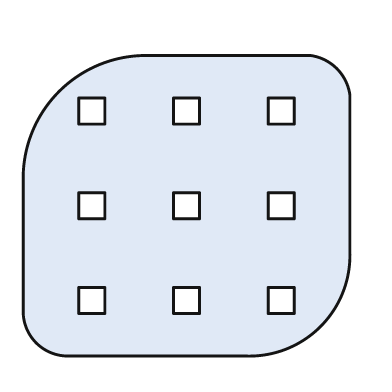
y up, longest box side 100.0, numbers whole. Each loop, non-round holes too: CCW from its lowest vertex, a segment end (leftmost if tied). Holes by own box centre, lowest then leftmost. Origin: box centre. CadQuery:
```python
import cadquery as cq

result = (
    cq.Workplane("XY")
    .moveTo(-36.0, -46.0)
    .lineTo(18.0, -46.0)
    .threePointArc((41.0, -37.0), (50.0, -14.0))
    .lineTo(50.0, 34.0)
    .threePointArc((46.0, 42.0), (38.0, 46.0))
    .lineTo(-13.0, 46.0)
    .threePointArc((-39.0, 35.0), (-50.0, 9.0))
    .lineTo(-50.0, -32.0)
    .threePointArc((-46.0, -42.0), (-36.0, -46.0))
    .close()
    .moveTo(-33.0, -33.0)
    .lineTo(-25.0, -33.0)
    .lineTo(-25.0, -25.0)
    .lineTo(-33.0, -25.0)
    .close()
    .moveTo(-4.0, -33.0)
    .lineTo(4.0, -33.0)
    .lineTo(4.0, -25.0)
    .lineTo(-4.0, -25.0)
    .close()
    .moveTo(25.0, -33.0)
    .lineTo(33.0, -33.0)
    .lineTo(33.0, -25.0)
    .lineTo(25.0, -25.0)
    .close()
    .moveTo(-33.0, -4.0)
    .lineTo(-25.0, -4.0)
    .lineTo(-25.0, 4.0)
    .lineTo(-33.0, 4.0)
    .close()
    .moveTo(-4.0, -4.0)
    .lineTo(4.0, -4.0)
    .lineTo(4.0, 4.0)
    .lineTo(-4.0, 4.0)
    .close()
    .moveTo(25.0, -4.0)
    .lineTo(33.0, -4.0)
    .lineTo(33.0, 4.0)
    .lineTo(25.0, 4.0)
    .close()
    .moveTo(-33.0, 25.0)
    .lineTo(-25.0, 25.0)
    .lineTo(-25.0, 33.0)
    .lineTo(-33.0, 33.0)
    .close()
    .moveTo(-4.0, 25.0)
    .lineTo(4.0, 25.0)
    .lineTo(4.0, 33.0)
    .lineTo(-4.0, 33.0)
    .close()
    .moveTo(25.0, 25.0)
    .lineTo(33.0, 25.0)
    .lineTo(33.0, 33.0)
    .lineTo(25.0, 33.0)
    .close()
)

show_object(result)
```